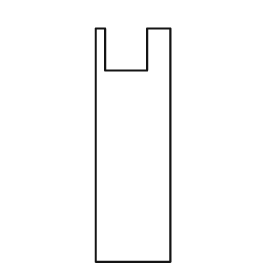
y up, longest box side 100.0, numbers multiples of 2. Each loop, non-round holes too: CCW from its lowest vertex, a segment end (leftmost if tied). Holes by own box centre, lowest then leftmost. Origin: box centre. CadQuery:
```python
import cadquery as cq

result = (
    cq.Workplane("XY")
    .moveTo(-16.0, -50.0)
    .lineTo(16.0, -50.0)
    .lineTo(16.0, 50.0)
    .lineTo(6.0, 50.0)
    .lineTo(6.0, 32.0)
    .lineTo(-12.0, 32.0)
    .lineTo(-12.0, 50.0)
    .lineTo(-16.0, 50.0)
    .close()
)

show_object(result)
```